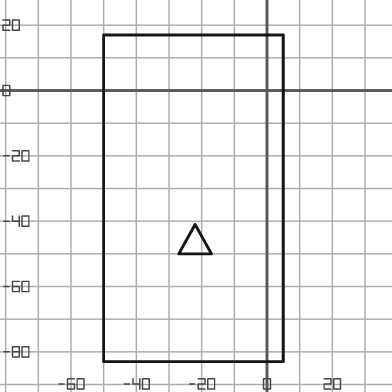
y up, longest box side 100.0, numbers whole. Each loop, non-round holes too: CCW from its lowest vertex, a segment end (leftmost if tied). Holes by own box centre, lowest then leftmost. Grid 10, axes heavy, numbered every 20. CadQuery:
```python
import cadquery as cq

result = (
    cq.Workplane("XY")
    .moveTo(-50.0, -83.0)
    .lineTo(5.0, -83.0)
    .lineTo(5.0, 17.0)
    .lineTo(-50.0, 17.0)
    .close()
    .moveTo(-27.0, -50.0)
    .lineTo(-17.0, -50.0)
    .lineTo(-22.0, -41.0)
    .close()
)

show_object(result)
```